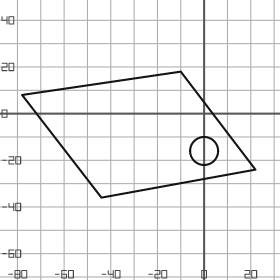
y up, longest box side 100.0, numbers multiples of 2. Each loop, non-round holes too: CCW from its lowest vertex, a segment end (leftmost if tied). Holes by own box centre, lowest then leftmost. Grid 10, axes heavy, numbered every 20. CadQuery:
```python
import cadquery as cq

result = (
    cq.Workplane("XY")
    .moveTo(-44.0, -36.0)
    .lineTo(22.0, -24.0)
    .lineTo(-10.0, 18.0)
    .lineTo(-78.0, 8.0)
    .close()
    .moveTo(0.0, -16.0)
    .circle(6.0)
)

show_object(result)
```